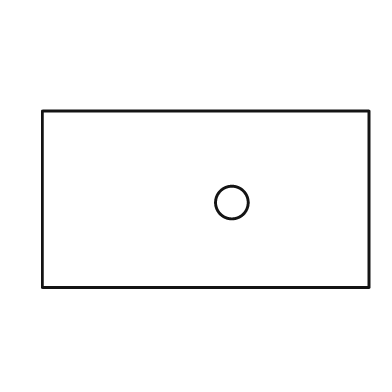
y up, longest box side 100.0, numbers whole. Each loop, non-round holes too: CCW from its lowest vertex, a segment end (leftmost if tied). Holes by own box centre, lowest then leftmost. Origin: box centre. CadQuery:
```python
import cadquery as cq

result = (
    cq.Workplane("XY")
    .moveTo(-50.0, -27.0)
    .lineTo(50.0, -27.0)
    .lineTo(50.0, 27.0)
    .lineTo(-50.0, 27.0)
    .close()
    .moveTo(8.0, -1.0)
    .circle(5.0)
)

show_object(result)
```